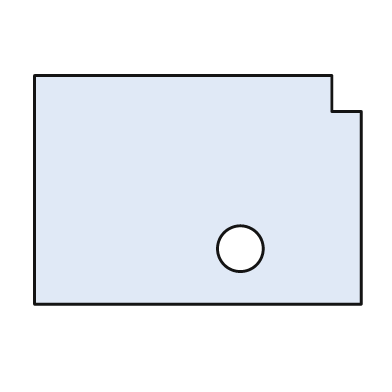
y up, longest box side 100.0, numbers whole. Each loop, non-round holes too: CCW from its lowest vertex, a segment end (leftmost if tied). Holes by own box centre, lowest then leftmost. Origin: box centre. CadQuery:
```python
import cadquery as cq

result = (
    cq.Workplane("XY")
    .moveTo(-50.0, -35.0)
    .lineTo(50.0, -35.0)
    .lineTo(50.0, 24.0)
    .lineTo(41.0, 24.0)
    .lineTo(41.0, 35.0)
    .lineTo(-50.0, 35.0)
    .close()
    .moveTo(13.0, -18.0)
    .circle(7.0)
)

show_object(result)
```